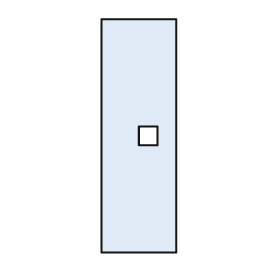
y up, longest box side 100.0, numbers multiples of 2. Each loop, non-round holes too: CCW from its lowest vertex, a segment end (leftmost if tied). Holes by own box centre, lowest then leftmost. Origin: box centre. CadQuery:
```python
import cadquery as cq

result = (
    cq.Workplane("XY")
    .moveTo(-16.0, -50.0)
    .lineTo(16.0, -50.0)
    .lineTo(16.0, 50.0)
    .lineTo(-16.0, 50.0)
    .close()
    .moveTo(0.0, -4.0)
    .lineTo(8.0, -4.0)
    .lineTo(8.0, 4.0)
    .lineTo(0.0, 4.0)
    .close()
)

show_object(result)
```